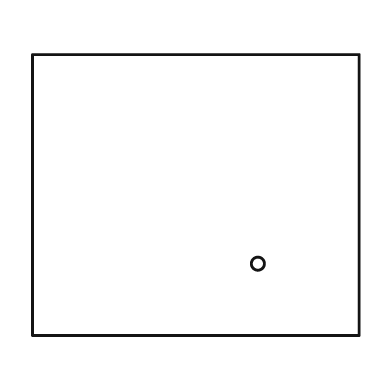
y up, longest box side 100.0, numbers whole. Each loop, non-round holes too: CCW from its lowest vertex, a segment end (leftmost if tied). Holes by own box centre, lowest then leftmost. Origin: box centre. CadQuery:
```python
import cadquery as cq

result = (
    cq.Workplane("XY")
    .moveTo(-50.0, -43.0)
    .lineTo(50.0, -43.0)
    .lineTo(50.0, 43.0)
    .lineTo(-50.0, 43.0)
    .close()
    .moveTo(19.0, -21.0)
    .circle(2.0)
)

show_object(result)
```